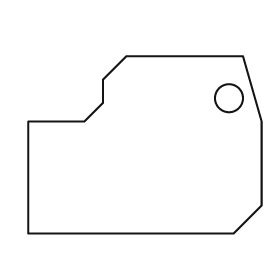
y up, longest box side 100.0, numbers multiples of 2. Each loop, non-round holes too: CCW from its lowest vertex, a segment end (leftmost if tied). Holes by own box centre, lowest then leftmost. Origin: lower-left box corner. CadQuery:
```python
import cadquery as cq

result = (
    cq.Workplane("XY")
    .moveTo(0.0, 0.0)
    .lineTo(88.0, 0.0)
    .lineTo(100.0, 12.0)
    .lineTo(100.0, 48.0)
    .lineTo(92.0, 76.0)
    .lineTo(42.0, 76.0)
    .lineTo(32.0, 66.0)
    .lineTo(32.0, 56.0)
    .lineTo(24.0, 48.0)
    .lineTo(0.0, 48.0)
    .close()
    .moveTo(86.0, 58.0)
    .circle(6.0)
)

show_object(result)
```